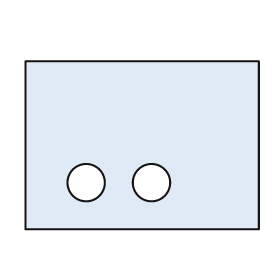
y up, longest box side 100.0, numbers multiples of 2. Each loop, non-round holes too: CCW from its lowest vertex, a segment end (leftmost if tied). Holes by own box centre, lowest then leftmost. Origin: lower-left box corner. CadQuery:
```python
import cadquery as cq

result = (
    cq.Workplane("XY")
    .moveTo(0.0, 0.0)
    .lineTo(100.0, 0.0)
    .lineTo(100.0, 72.0)
    .lineTo(0.0, 72.0)
    .close()
    .moveTo(26.0, 20.0)
    .circle(8.0)
    .moveTo(54.0, 20.0)
    .circle(8.0)
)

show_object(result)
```